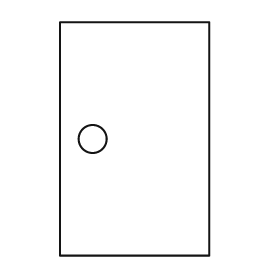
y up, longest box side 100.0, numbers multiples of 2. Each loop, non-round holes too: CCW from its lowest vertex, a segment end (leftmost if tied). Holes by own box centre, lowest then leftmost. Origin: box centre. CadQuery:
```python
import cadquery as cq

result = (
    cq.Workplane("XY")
    .moveTo(-32.0, -50.0)
    .lineTo(32.0, -50.0)
    .lineTo(32.0, 50.0)
    .lineTo(-32.0, 50.0)
    .close()
    .moveTo(-18.0, 0.0)
    .circle(6.0)
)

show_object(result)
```